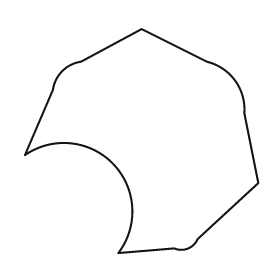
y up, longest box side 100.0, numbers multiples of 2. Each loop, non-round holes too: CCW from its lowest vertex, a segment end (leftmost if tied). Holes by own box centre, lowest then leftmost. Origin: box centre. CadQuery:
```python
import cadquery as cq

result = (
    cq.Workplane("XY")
    .moveTo(-10.0, -48.0)
    .lineTo(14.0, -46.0)
    .threePointArc((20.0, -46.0), (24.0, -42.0))
    .lineTo(50.0, -18.0)
    .lineTo(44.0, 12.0)
    .threePointArc((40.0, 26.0), (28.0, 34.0))
    .lineTo(0.0, 48.0)
    .lineTo(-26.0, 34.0)
    .threePointArc((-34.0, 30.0), (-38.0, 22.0))
    .lineTo(-50.0, -6.0)
    .threePointArc((-12.0, -10.0), (-10.0, -48.0))
    .close()
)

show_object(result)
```